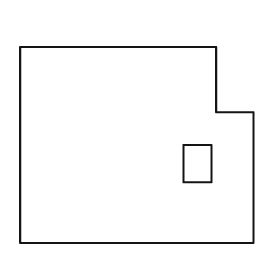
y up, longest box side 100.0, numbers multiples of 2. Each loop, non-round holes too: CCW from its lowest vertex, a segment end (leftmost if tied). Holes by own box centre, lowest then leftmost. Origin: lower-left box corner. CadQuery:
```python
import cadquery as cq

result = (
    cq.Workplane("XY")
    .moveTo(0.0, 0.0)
    .lineTo(100.0, 0.0)
    .lineTo(100.0, 56.0)
    .lineTo(84.0, 56.0)
    .lineTo(84.0, 84.0)
    .lineTo(0.0, 84.0)
    .close()
    .moveTo(70.0, 26.0)
    .lineTo(82.0, 26.0)
    .lineTo(82.0, 42.0)
    .lineTo(70.0, 42.0)
    .close()
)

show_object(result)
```